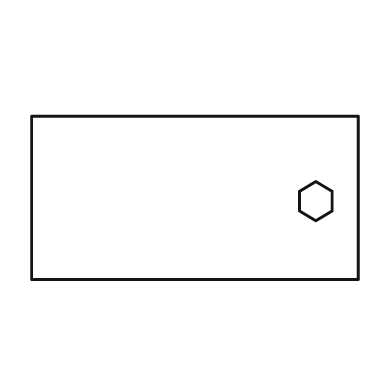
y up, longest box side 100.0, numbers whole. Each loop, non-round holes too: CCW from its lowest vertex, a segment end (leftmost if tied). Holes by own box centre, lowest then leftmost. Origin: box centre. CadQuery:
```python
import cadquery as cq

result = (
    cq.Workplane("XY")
    .moveTo(-50.0, -25.0)
    .lineTo(50.0, -25.0)
    .lineTo(50.0, 25.0)
    .lineTo(-50.0, 25.0)
    .close()
    .moveTo(37.0, -7.0)
    .lineTo(42.0, -4.0)
    .lineTo(42.0, 2.0)
    .lineTo(37.0, 5.0)
    .lineTo(32.0, 2.0)
    .lineTo(32.0, -4.0)
    .close()
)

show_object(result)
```